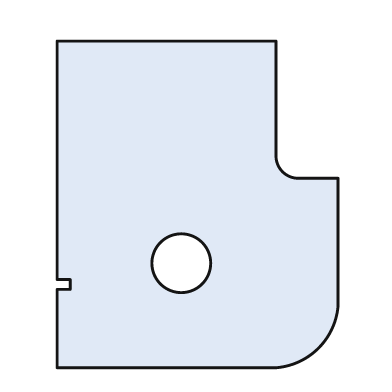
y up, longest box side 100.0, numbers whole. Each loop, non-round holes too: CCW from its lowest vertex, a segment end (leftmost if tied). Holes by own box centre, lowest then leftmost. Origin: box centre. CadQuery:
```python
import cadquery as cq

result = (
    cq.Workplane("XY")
    .moveTo(-43.0, -50.0)
    .lineTo(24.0, -50.0)
    .threePointArc((37.0, -44.0), (43.0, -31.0))
    .lineTo(43.0, 8.0)
    .lineTo(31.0, 8.0)
    .threePointArc((26.0, 10.0), (24.0, 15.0))
    .lineTo(24.0, 50.0)
    .lineTo(-43.0, 50.0)
    .lineTo(-43.0, -23.0)
    .lineTo(-39.0, -23.0)
    .lineTo(-39.0, -26.0)
    .lineTo(-43.0, -26.0)
    .close()
    .moveTo(-5.0, -18.0)
    .circle(9.0)
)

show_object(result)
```